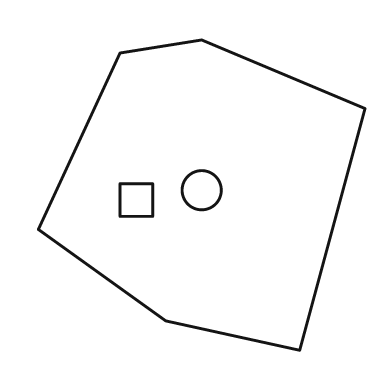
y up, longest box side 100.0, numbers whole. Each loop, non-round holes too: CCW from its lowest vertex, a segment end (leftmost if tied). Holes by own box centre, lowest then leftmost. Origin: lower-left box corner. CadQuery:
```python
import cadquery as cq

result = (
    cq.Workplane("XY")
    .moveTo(80.0, 0.0)
    .lineTo(100.0, 74.0)
    .lineTo(50.0, 95.0)
    .lineTo(25.0, 91.0)
    .lineTo(0.0, 37.0)
    .lineTo(39.0, 9.0)
    .close()
    .moveTo(25.0, 41.0)
    .lineTo(35.0, 41.0)
    .lineTo(35.0, 51.0)
    .lineTo(25.0, 51.0)
    .close()
    .moveTo(50.0, 49.0)
    .circle(6.0)
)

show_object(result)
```